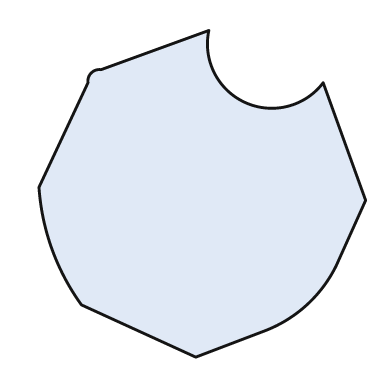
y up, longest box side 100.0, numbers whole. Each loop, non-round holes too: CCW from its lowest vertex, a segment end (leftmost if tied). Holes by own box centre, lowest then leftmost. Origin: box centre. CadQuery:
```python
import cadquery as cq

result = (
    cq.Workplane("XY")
    .moveTo(-2.0, -50.0)
    .lineTo(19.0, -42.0)
    .threePointArc((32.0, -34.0), (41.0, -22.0))
    .lineTo(50.0, -2.0)
    .lineTo(37.0, 34.0)
    .threePointArc((13.0, 28.0), (2.0, 50.0))
    .lineTo(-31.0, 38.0)
    .threePointArc((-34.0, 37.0), (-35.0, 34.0))
    .lineTo(-50.0, 2.0)
    .threePointArc((-46.0, -17.0), (-37.0, -34.0))
    .close()
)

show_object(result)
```